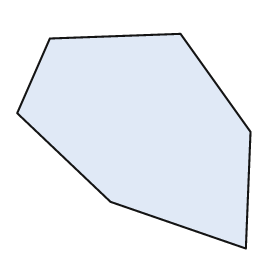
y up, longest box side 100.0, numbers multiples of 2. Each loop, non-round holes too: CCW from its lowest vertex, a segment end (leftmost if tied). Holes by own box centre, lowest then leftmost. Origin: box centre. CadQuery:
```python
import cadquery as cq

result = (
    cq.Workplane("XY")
    .moveTo(48.0, -46.0)
    .lineTo(50.0, 4.0)
    .lineTo(20.0, 46.0)
    .lineTo(-36.0, 44.0)
    .lineTo(-50.0, 12.0)
    .lineTo(-10.0, -26.0)
    .close()
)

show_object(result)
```